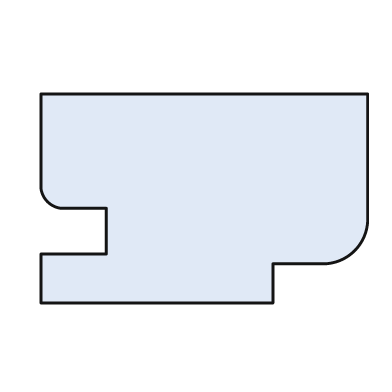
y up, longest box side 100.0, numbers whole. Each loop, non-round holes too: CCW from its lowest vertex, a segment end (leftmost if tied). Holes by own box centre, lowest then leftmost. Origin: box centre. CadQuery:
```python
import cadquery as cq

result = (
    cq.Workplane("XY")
    .moveTo(-50.0, -32.0)
    .lineTo(21.0, -32.0)
    .lineTo(21.0, -20.0)
    .lineTo(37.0, -20.0)
    .threePointArc((46.0, -16.0), (50.0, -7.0))
    .lineTo(50.0, 32.0)
    .lineTo(-50.0, 32.0)
    .lineTo(-50.0, 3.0)
    .threePointArc((-48.0, -1.0), (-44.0, -3.0))
    .lineTo(-30.0, -3.0)
    .lineTo(-30.0, -17.0)
    .lineTo(-50.0, -17.0)
    .close()
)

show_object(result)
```